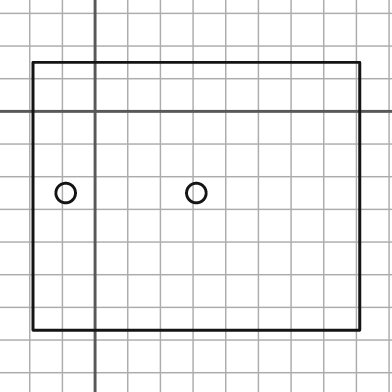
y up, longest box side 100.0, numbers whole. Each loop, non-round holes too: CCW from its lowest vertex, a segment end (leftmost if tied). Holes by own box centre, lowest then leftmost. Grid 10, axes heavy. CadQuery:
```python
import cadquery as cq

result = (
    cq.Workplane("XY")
    .moveTo(-19.0, -67.0)
    .lineTo(81.0, -67.0)
    .lineTo(81.0, 15.0)
    .lineTo(-19.0, 15.0)
    .close()
    .moveTo(-9.0, -25.0)
    .circle(3.0)
    .moveTo(31.0, -25.0)
    .circle(3.0)
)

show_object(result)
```